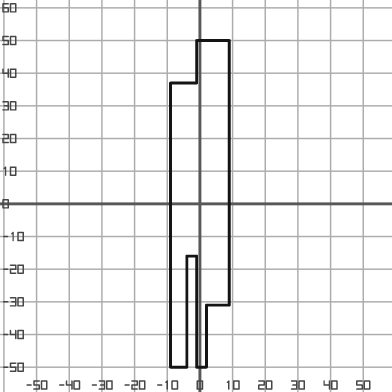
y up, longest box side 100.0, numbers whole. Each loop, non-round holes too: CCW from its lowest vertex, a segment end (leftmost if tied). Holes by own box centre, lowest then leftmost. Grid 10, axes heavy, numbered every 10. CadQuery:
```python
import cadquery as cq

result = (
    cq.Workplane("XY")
    .moveTo(-9.0, -50.0)
    .lineTo(-4.0, -50.0)
    .lineTo(-4.0, -16.0)
    .lineTo(-1.0, -16.0)
    .lineTo(-1.0, -50.0)
    .lineTo(2.0, -50.0)
    .lineTo(2.0, -31.0)
    .lineTo(9.0, -31.0)
    .lineTo(9.0, 50.0)
    .lineTo(-1.0, 50.0)
    .lineTo(-1.0, 37.0)
    .lineTo(-9.0, 37.0)
    .close()
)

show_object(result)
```